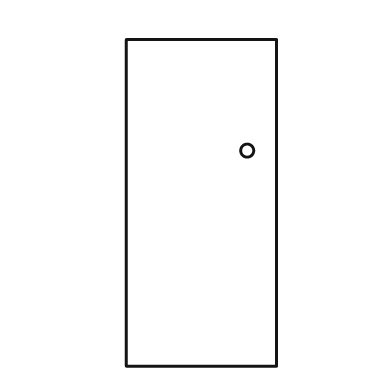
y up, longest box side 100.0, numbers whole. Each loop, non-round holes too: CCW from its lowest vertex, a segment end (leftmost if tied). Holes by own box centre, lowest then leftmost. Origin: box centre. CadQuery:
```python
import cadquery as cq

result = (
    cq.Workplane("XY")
    .moveTo(-23.0, -50.0)
    .lineTo(23.0, -50.0)
    .lineTo(23.0, 50.0)
    .lineTo(-23.0, 50.0)
    .close()
    .moveTo(14.0, 16.0)
    .circle(2.0)
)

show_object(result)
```